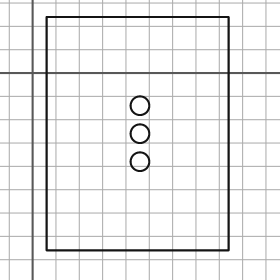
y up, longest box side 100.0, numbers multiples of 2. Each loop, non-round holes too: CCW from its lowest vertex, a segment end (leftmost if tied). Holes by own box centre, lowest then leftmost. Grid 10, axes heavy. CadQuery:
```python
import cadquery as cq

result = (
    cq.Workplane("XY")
    .moveTo(6.0, -76.0)
    .lineTo(84.0, -76.0)
    .lineTo(84.0, 24.0)
    .lineTo(6.0, 24.0)
    .close()
    .moveTo(46.0, -38.0)
    .circle(4.0)
    .moveTo(46.0, -26.0)
    .circle(4.0)
    .moveTo(46.0, -14.0)
    .circle(4.0)
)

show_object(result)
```